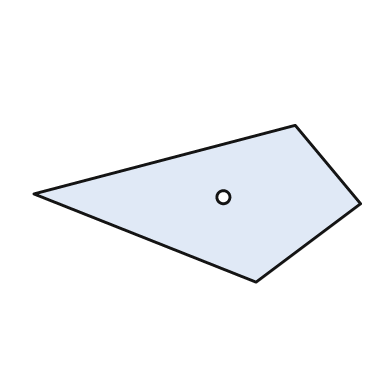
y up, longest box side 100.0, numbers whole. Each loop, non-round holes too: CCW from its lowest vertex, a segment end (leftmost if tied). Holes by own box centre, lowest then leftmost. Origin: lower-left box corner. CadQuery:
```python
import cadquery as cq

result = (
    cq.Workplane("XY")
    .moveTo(68.0, 0.0)
    .lineTo(100.0, 24.0)
    .lineTo(80.0, 48.0)
    .lineTo(0.0, 27.0)
    .close()
    .moveTo(58.0, 26.0)
    .circle(2.0)
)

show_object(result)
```